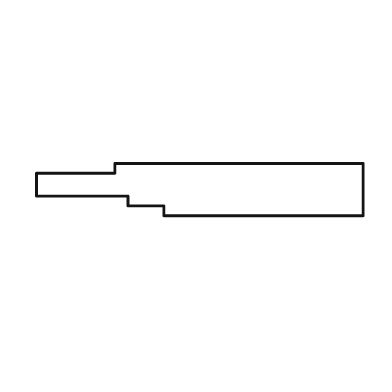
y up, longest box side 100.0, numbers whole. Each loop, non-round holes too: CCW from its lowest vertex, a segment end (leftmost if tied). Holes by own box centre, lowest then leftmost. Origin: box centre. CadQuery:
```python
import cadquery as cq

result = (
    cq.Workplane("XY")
    .moveTo(-11.0, -8.0)
    .lineTo(50.0, -8.0)
    .lineTo(50.0, 8.0)
    .lineTo(-26.0, 8.0)
    .lineTo(-26.0, 5.0)
    .lineTo(-50.0, 5.0)
    .lineTo(-50.0, -2.0)
    .lineTo(-22.0, -2.0)
    .lineTo(-22.0, -5.0)
    .lineTo(-11.0, -5.0)
    .close()
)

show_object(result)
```